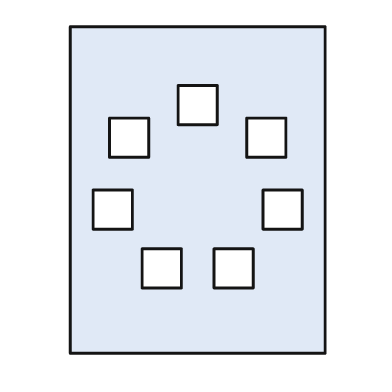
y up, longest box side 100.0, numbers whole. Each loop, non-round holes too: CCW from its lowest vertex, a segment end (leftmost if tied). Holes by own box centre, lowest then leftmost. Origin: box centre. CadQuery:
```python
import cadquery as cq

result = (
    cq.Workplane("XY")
    .moveTo(-39.0, -50.0)
    .lineTo(39.0, -50.0)
    .lineTo(39.0, 50.0)
    .lineTo(-39.0, 50.0)
    .close()
    .moveTo(-17.0, -30.0)
    .lineTo(-5.0, -30.0)
    .lineTo(-5.0, -18.0)
    .lineTo(-17.0, -18.0)
    .close()
    .moveTo(5.0, -30.0)
    .lineTo(17.0, -30.0)
    .lineTo(17.0, -18.0)
    .lineTo(5.0, -18.0)
    .close()
    .moveTo(-32.0, -12.0)
    .lineTo(-20.0, -12.0)
    .lineTo(-20.0, 0.0)
    .lineTo(-32.0, 0.0)
    .close()
    .moveTo(20.0, -12.0)
    .lineTo(32.0, -12.0)
    .lineTo(32.0, 0.0)
    .lineTo(20.0, 0.0)
    .close()
    .moveTo(-27.0, 10.0)
    .lineTo(-15.0, 10.0)
    .lineTo(-15.0, 22.0)
    .lineTo(-27.0, 22.0)
    .close()
    .moveTo(15.0, 10.0)
    .lineTo(27.0, 10.0)
    .lineTo(27.0, 22.0)
    .lineTo(15.0, 22.0)
    .close()
    .moveTo(-6.0, 20.0)
    .lineTo(6.0, 20.0)
    .lineTo(6.0, 32.0)
    .lineTo(-6.0, 32.0)
    .close()
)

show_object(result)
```